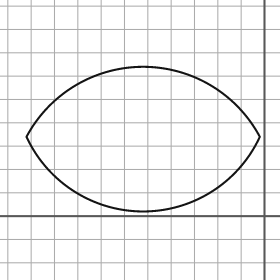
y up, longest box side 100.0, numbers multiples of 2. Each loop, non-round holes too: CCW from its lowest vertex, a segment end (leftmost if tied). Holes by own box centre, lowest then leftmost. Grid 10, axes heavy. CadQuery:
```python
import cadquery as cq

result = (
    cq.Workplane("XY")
    .moveTo(-102.0, 34.0)
    .threePointArc((-52.0, 2.0), (-2.0, 34.0))
    .threePointArc((-52.0, 64.0), (-102.0, 34.0))
    .close()
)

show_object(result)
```